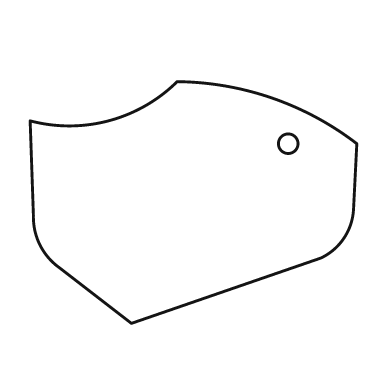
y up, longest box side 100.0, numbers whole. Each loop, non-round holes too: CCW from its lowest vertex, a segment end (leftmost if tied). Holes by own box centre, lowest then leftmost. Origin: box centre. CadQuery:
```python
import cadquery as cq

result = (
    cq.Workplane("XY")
    .moveTo(-19.0, -37.0)
    .lineTo(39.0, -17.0)
    .threePointArc((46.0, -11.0), (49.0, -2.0))
    .lineTo(50.0, 18.0)
    .threePointArc((24.0, 32.0), (-5.0, 37.0))
    .threePointArc((-26.0, 25.0), (-50.0, 25.0))
    .lineTo(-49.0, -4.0)
    .threePointArc((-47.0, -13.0), (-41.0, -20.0))
    .close()
    .moveTo(29.0, 18.0)
    .circle(3.0)
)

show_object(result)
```